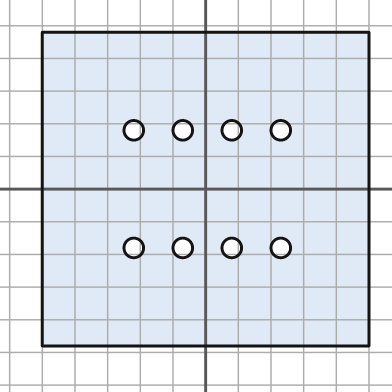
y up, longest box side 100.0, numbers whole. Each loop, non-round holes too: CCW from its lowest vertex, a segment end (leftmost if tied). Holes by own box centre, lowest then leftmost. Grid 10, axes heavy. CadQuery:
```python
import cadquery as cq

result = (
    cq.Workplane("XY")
    .moveTo(-50.0, -48.0)
    .lineTo(50.0, -48.0)
    .lineTo(50.0, 48.0)
    .lineTo(-50.0, 48.0)
    .close()
    .moveTo(-22.0, -18.0)
    .circle(3.0)
    .moveTo(-7.0, -18.0)
    .circle(3.0)
    .moveTo(8.0, -18.0)
    .circle(3.0)
    .moveTo(23.0, -18.0)
    .circle(3.0)
    .moveTo(-22.0, 18.0)
    .circle(3.0)
    .moveTo(-7.0, 18.0)
    .circle(3.0)
    .moveTo(8.0, 18.0)
    .circle(3.0)
    .moveTo(23.0, 18.0)
    .circle(3.0)
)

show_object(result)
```